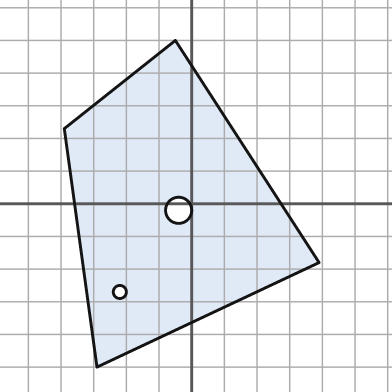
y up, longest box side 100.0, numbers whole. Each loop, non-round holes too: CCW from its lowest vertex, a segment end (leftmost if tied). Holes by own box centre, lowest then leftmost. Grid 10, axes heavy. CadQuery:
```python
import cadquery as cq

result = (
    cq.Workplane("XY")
    .moveTo(-29.0, -50.0)
    .lineTo(39.0, -18.0)
    .lineTo(-5.0, 50.0)
    .lineTo(-39.0, 23.0)
    .close()
    .moveTo(-22.0, -27.0)
    .circle(2.0)
    .moveTo(-4.0, -2.0)
    .circle(4.0)
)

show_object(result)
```